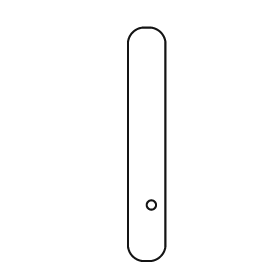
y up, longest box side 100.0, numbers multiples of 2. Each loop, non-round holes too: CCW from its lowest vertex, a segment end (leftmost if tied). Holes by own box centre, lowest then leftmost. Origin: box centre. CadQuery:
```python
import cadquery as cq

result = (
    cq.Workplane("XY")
    .moveTo(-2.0, -50.0)
    .lineTo(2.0, -50.0)
    .threePointArc((6.0, -48.0), (8.0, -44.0))
    .lineTo(8.0, 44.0)
    .threePointArc((6.0, 48.0), (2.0, 50.0))
    .lineTo(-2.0, 50.0)
    .threePointArc((-6.0, 48.0), (-8.0, 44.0))
    .lineTo(-8.0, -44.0)
    .threePointArc((-6.0, -48.0), (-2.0, -50.0))
    .close()
    .moveTo(2.0, -26.0)
    .circle(2.0)
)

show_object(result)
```